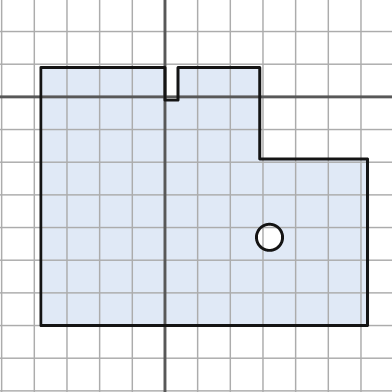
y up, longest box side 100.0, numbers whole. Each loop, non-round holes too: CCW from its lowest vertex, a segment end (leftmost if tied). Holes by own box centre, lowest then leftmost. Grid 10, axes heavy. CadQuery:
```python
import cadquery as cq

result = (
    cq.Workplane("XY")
    .moveTo(-38.0, -70.0)
    .lineTo(62.0, -70.0)
    .lineTo(62.0, -19.0)
    .lineTo(29.0, -19.0)
    .lineTo(29.0, 9.0)
    .lineTo(4.0, 9.0)
    .lineTo(4.0, -1.0)
    .lineTo(0.0, -1.0)
    .lineTo(0.0, 9.0)
    .lineTo(-38.0, 9.0)
    .close()
    .moveTo(32.0, -43.0)
    .circle(4.0)
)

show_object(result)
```